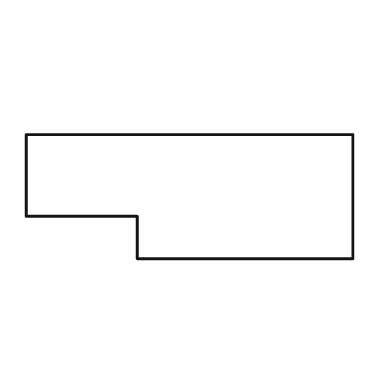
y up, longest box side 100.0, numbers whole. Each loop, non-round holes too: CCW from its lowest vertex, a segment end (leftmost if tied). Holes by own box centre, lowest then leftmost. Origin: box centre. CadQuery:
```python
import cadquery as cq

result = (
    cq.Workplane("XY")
    .moveTo(-16.0, -19.0)
    .lineTo(50.0, -19.0)
    .lineTo(50.0, 19.0)
    .lineTo(-50.0, 19.0)
    .lineTo(-50.0, -6.0)
    .lineTo(-16.0, -6.0)
    .close()
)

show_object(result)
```